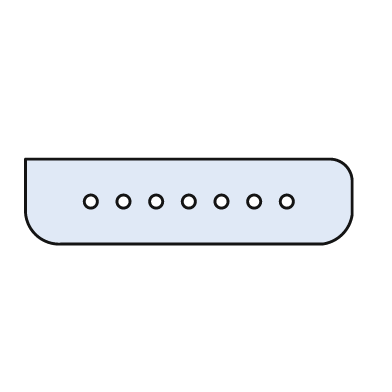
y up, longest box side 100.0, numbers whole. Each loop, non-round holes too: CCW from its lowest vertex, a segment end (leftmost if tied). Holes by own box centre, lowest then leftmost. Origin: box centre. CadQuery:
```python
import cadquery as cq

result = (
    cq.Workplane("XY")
    .moveTo(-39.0, -13.0)
    .lineTo(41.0, -13.0)
    .threePointArc((47.0, -10.0), (50.0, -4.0))
    .lineTo(50.0, 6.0)
    .threePointArc((48.0, 11.0), (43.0, 13.0))
    .lineTo(-50.0, 13.0)
    .lineTo(-50.0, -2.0)
    .threePointArc((-47.0, -10.0), (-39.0, -13.0))
    .close()
    .moveTo(-30.0, 0.0)
    .circle(2.0)
    .moveTo(-20.0, 0.0)
    .circle(2.0)
    .moveTo(-10.0, 0.0)
    .circle(2.0)
    .moveTo(0.0, 0.0)
    .circle(2.0)
    .moveTo(10.0, 0.0)
    .circle(2.0)
    .moveTo(20.0, 0.0)
    .circle(2.0)
    .moveTo(30.0, 0.0)
    .circle(2.0)
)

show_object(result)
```